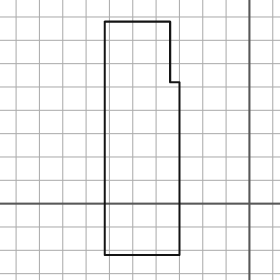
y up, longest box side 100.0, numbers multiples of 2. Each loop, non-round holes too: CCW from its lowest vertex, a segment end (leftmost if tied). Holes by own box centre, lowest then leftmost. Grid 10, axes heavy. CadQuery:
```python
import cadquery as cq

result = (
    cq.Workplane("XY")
    .moveTo(-62.0, -22.0)
    .lineTo(-30.0, -22.0)
    .lineTo(-30.0, 52.0)
    .lineTo(-34.0, 52.0)
    .lineTo(-34.0, 78.0)
    .lineTo(-62.0, 78.0)
    .close()
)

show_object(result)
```